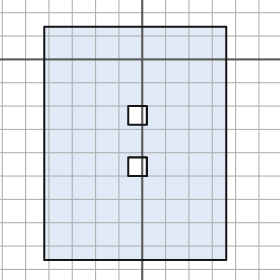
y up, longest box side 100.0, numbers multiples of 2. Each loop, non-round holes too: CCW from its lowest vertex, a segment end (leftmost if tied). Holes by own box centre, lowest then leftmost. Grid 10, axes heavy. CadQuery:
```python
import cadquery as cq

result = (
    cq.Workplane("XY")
    .moveTo(-42.0, -86.0)
    .lineTo(36.0, -86.0)
    .lineTo(36.0, 14.0)
    .lineTo(-42.0, 14.0)
    .close()
    .moveTo(-6.0, -50.0)
    .lineTo(2.0, -50.0)
    .lineTo(2.0, -42.0)
    .lineTo(-6.0, -42.0)
    .close()
    .moveTo(-6.0, -28.0)
    .lineTo(2.0, -28.0)
    .lineTo(2.0, -20.0)
    .lineTo(-6.0, -20.0)
    .close()
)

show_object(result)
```